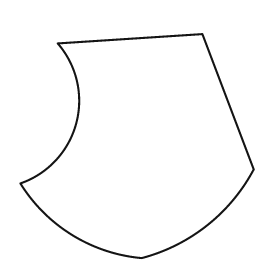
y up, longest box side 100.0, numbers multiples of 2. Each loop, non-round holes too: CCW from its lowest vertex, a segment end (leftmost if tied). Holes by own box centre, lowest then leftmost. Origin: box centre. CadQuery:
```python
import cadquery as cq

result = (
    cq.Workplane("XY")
    .moveTo(2.0, -48.0)
    .threePointArc((30.0, -34.0), (50.0, -10.0))
    .lineTo(28.0, 48.0)
    .lineTo(-34.0, 44.0)
    .threePointArc((-26.0, 10.0), (-50.0, -16.0))
    .threePointArc((-28.0, -38.0), (2.0, -48.0))
    .close()
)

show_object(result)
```